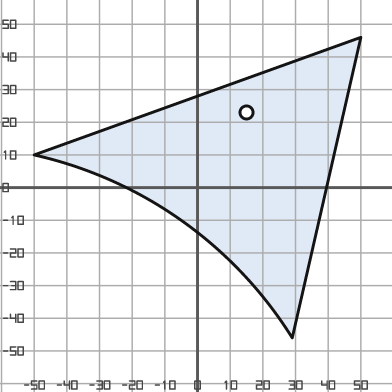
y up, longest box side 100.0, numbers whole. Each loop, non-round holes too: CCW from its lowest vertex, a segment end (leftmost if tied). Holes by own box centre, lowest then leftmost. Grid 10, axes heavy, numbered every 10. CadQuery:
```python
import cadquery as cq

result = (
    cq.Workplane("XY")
    .moveTo(29.0, -46.0)
    .lineTo(50.0, 46.0)
    .lineTo(-50.0, 10.0)
    .threePointArc((-5.0, -10.0), (29.0, -46.0))
    .close()
    .moveTo(15.0, 23.0)
    .circle(2.0)
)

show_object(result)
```